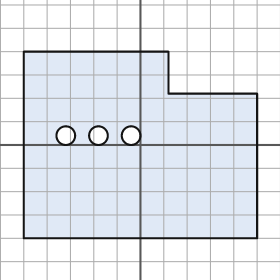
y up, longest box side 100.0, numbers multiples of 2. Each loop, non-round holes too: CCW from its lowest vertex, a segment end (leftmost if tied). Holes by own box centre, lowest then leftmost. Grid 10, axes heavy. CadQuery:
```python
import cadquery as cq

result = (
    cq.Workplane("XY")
    .moveTo(-50.0, -40.0)
    .lineTo(50.0, -40.0)
    .lineTo(50.0, 22.0)
    .lineTo(12.0, 22.0)
    .lineTo(12.0, 40.0)
    .lineTo(-50.0, 40.0)
    .close()
    .moveTo(-32.0, 4.0)
    .circle(4.0)
    .moveTo(-18.0, 4.0)
    .circle(4.0)
    .moveTo(-4.0, 4.0)
    .circle(4.0)
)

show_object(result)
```